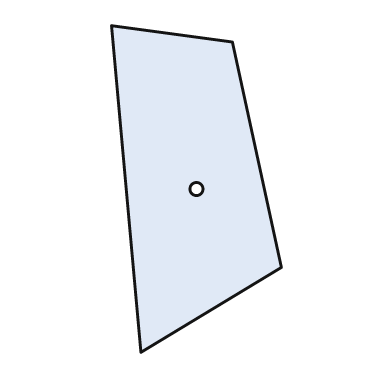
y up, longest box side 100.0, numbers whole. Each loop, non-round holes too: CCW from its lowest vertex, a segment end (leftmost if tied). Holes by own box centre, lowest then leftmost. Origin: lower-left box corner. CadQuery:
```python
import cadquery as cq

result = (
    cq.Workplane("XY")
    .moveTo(9.0, 0.0)
    .lineTo(52.0, 26.0)
    .lineTo(37.0, 95.0)
    .lineTo(0.0, 100.0)
    .close()
    .moveTo(26.0, 50.0)
    .circle(2.0)
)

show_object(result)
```